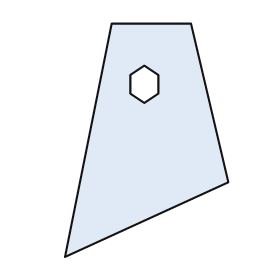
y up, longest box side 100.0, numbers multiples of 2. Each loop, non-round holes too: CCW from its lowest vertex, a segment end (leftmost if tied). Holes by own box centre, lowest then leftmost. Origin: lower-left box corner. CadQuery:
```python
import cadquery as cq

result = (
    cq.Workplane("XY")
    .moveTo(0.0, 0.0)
    .lineTo(70.0, 32.0)
    .lineTo(54.0, 100.0)
    .lineTo(20.0, 100.0)
    .close()
    .moveTo(34.0, 66.0)
    .lineTo(40.0, 70.0)
    .lineTo(40.0, 78.0)
    .lineTo(34.0, 82.0)
    .lineTo(28.0, 78.0)
    .lineTo(28.0, 70.0)
    .close()
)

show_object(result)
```